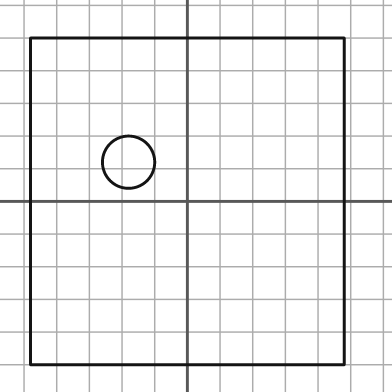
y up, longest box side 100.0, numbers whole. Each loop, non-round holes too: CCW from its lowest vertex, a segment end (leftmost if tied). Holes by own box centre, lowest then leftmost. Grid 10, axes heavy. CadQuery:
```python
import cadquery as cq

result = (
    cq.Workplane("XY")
    .moveTo(-48.0, -50.0)
    .lineTo(48.0, -50.0)
    .lineTo(48.0, 50.0)
    .lineTo(-48.0, 50.0)
    .close()
    .moveTo(-18.0, 12.0)
    .circle(8.0)
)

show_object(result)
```